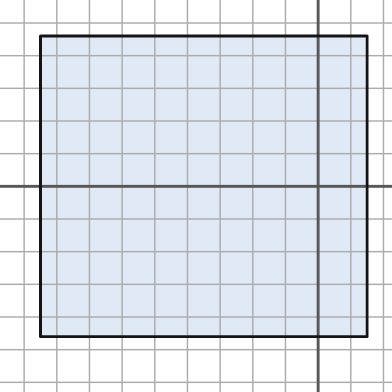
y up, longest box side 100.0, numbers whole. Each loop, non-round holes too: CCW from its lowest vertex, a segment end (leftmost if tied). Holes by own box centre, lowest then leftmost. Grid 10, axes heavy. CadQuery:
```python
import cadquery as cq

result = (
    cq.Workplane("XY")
    .moveTo(-85.0, -46.0)
    .lineTo(15.0, -46.0)
    .lineTo(15.0, 46.0)
    .lineTo(-85.0, 46.0)
    .close()
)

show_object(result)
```